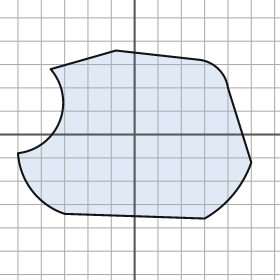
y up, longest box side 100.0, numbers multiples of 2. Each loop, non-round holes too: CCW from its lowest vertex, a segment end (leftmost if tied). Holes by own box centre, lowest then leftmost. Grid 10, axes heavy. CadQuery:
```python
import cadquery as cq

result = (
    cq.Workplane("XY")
    .moveTo(30.0, -36.0)
    .threePointArc((42.0, -26.0), (50.0, -12.0))
    .lineTo(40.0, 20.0)
    .threePointArc((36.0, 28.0), (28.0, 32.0))
    .lineTo(-8.0, 36.0)
    .lineTo(-36.0, 28.0)
    .threePointArc((-32.0, 6.0), (-50.0, -8.0))
    .threePointArc((-44.0, -24.0), (-30.0, -34.0))
    .close()
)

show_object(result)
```